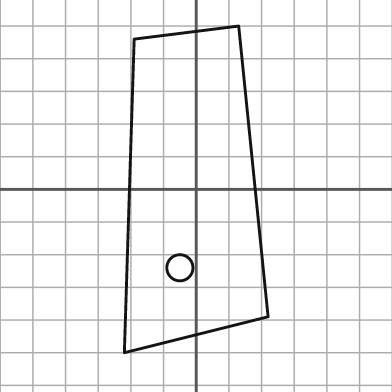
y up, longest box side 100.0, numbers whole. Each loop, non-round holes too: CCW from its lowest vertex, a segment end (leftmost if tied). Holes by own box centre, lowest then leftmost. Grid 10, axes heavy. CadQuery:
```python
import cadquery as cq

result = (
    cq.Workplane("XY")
    .moveTo(-22.0, -50.0)
    .lineTo(22.0, -39.0)
    .lineTo(13.0, 50.0)
    .lineTo(-19.0, 46.0)
    .close()
    .moveTo(-5.0, -24.0)
    .circle(4.0)
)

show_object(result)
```